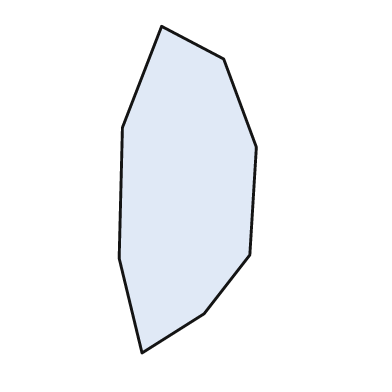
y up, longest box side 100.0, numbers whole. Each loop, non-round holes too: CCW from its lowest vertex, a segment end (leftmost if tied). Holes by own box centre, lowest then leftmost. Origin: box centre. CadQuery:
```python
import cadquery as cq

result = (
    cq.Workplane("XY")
    .moveTo(-14.0, -50.0)
    .lineTo(5.0, -38.0)
    .lineTo(19.0, -20.0)
    .lineTo(21.0, 13.0)
    .lineTo(11.0, 40.0)
    .lineTo(-8.0, 50.0)
    .lineTo(-20.0, 19.0)
    .lineTo(-21.0, -21.0)
    .close()
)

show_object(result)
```